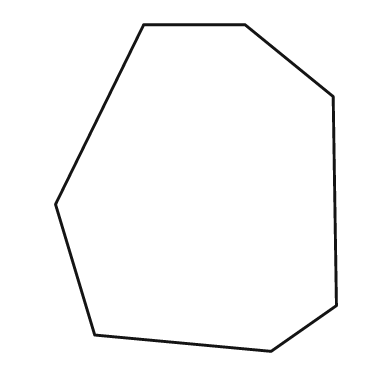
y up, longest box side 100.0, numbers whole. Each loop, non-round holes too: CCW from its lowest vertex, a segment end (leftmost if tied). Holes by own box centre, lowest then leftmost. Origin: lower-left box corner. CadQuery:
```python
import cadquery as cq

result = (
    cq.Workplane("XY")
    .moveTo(66.0, 0.0)
    .lineTo(86.0, 14.0)
    .lineTo(85.0, 78.0)
    .lineTo(58.0, 100.0)
    .lineTo(27.0, 100.0)
    .lineTo(0.0, 45.0)
    .lineTo(12.0, 5.0)
    .close()
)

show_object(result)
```